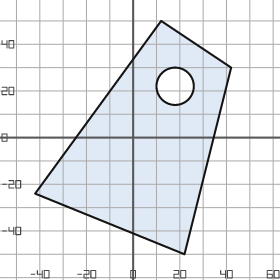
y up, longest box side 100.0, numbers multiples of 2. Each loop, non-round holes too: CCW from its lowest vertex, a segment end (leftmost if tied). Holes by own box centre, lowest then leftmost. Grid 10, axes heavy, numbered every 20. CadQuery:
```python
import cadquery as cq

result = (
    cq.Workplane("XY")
    .moveTo(22.0, -50.0)
    .lineTo(42.0, 30.0)
    .lineTo(12.0, 50.0)
    .lineTo(-42.0, -24.0)
    .close()
    .moveTo(18.0, 22.0)
    .circle(8.0)
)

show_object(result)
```